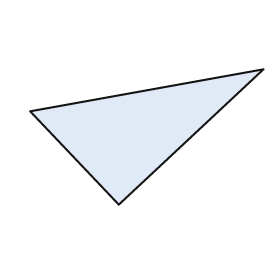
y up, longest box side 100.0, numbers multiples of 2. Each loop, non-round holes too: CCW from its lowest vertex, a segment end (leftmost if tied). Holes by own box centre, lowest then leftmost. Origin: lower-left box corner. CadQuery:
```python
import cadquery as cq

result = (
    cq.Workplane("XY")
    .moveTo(38.0, 0.0)
    .lineTo(100.0, 58.0)
    .lineTo(0.0, 40.0)
    .close()
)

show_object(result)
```